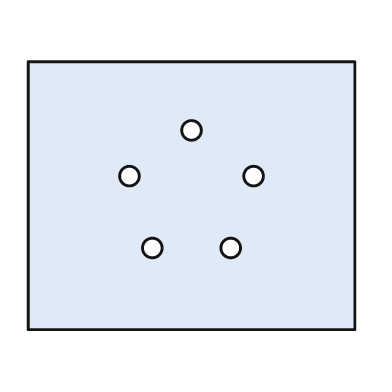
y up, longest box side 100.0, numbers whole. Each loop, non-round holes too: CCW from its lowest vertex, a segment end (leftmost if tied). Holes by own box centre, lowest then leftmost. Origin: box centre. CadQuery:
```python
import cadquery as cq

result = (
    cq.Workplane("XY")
    .moveTo(-50.0, -41.0)
    .lineTo(50.0, -41.0)
    .lineTo(50.0, 41.0)
    .lineTo(-50.0, 41.0)
    .close()
    .moveTo(-12.0, -16.0)
    .circle(3.0)
    .moveTo(12.0, -16.0)
    .circle(3.0)
    .moveTo(-19.0, 6.0)
    .circle(3.0)
    .moveTo(19.0, 6.0)
    .circle(3.0)
    .moveTo(0.0, 20.0)
    .circle(3.0)
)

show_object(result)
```